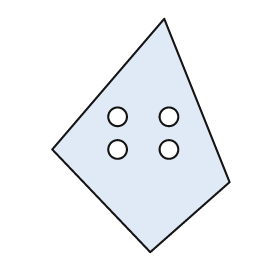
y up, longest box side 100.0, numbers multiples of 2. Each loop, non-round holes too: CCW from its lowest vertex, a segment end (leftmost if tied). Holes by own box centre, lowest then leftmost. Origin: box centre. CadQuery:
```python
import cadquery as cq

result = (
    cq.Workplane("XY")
    .moveTo(4.0, -50.0)
    .lineTo(38.0, -20.0)
    .lineTo(10.0, 50.0)
    .lineTo(-38.0, -6.0)
    .close()
    .moveTo(-10.0, -6.0)
    .circle(4.0)
    .moveTo(12.0, -6.0)
    .circle(4.0)
    .moveTo(-10.0, 8.0)
    .circle(4.0)
    .moveTo(12.0, 8.0)
    .circle(4.0)
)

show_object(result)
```